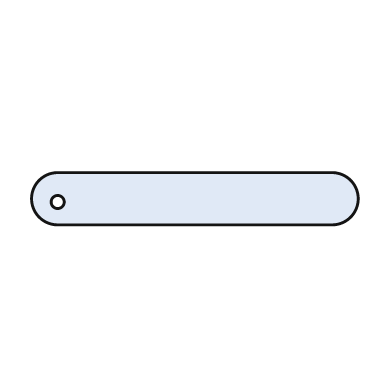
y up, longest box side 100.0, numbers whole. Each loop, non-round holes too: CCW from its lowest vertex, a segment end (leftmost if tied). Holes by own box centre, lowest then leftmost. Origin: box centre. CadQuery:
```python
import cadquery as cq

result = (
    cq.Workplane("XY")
    .moveTo(-42.0, -8.0)
    .lineTo(42.0, -8.0)
    .threePointArc((50.0, 0.0), (42.0, 8.0))
    .lineTo(-42.0, 8.0)
    .threePointArc((-50.0, 0.0), (-42.0, -8.0))
    .close()
    .moveTo(-42.0, -1.0)
    .circle(2.0)
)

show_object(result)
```